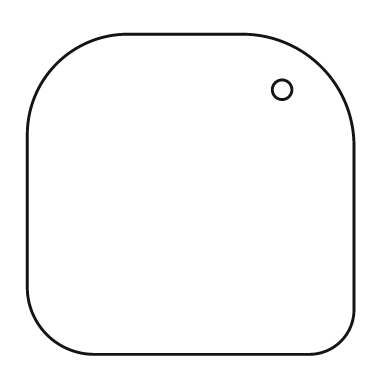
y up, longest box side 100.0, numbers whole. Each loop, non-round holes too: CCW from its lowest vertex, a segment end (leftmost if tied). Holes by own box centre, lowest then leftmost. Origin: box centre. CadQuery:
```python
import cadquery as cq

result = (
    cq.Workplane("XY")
    .moveTo(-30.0, -49.0)
    .lineTo(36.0, -49.0)
    .threePointArc((46.0, -45.0), (50.0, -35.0))
    .lineTo(50.0, 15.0)
    .threePointArc((40.0, 39.0), (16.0, 49.0))
    .lineTo(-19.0, 49.0)
    .threePointArc((-41.0, 40.0), (-50.0, 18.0))
    .lineTo(-50.0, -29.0)
    .threePointArc((-44.0, -43.0), (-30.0, -49.0))
    .close()
    .moveTo(28.0, 32.0)
    .circle(3.0)
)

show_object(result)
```